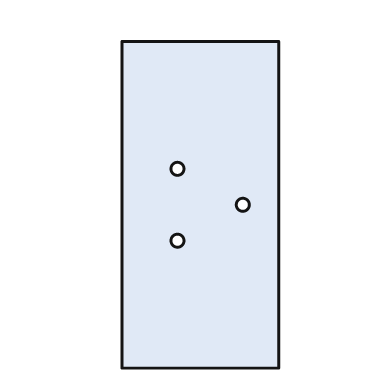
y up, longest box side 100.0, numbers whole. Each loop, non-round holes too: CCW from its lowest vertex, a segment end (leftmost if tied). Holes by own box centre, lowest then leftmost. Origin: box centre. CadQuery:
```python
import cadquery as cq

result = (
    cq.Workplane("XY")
    .moveTo(-24.0, -50.0)
    .lineTo(24.0, -50.0)
    .lineTo(24.0, 50.0)
    .lineTo(-24.0, 50.0)
    .close()
    .moveTo(-7.0, -11.0)
    .circle(2.0)
    .moveTo(13.0, 0.0)
    .circle(2.0)
    .moveTo(-7.0, 11.0)
    .circle(2.0)
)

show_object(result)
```